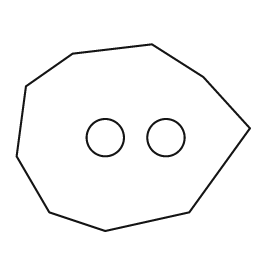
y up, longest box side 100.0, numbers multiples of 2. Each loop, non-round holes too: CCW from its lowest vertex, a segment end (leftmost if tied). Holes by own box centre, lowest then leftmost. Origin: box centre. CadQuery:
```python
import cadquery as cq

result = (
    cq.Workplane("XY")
    .moveTo(-12.0, -40.0)
    .lineTo(24.0, -32.0)
    .lineTo(50.0, 4.0)
    .lineTo(30.0, 26.0)
    .lineTo(8.0, 40.0)
    .lineTo(-26.0, 36.0)
    .lineTo(-46.0, 22.0)
    .lineTo(-50.0, -8.0)
    .lineTo(-36.0, -32.0)
    .close()
    .moveTo(-12.0, 0.0)
    .circle(8.0)
    .moveTo(14.0, 0.0)
    .circle(8.0)
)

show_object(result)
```